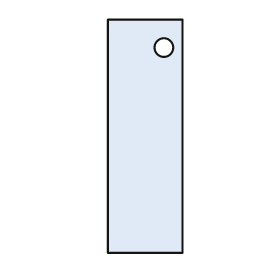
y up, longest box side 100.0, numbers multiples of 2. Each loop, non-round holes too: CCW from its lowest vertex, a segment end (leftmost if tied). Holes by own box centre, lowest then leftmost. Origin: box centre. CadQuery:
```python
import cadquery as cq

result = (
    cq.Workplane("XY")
    .moveTo(-16.0, -50.0)
    .lineTo(16.0, -50.0)
    .lineTo(16.0, 50.0)
    .lineTo(-16.0, 50.0)
    .close()
    .moveTo(8.0, 38.0)
    .circle(4.0)
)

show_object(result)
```